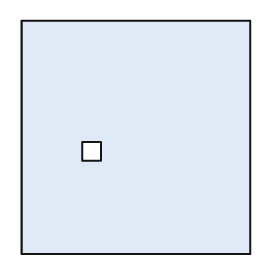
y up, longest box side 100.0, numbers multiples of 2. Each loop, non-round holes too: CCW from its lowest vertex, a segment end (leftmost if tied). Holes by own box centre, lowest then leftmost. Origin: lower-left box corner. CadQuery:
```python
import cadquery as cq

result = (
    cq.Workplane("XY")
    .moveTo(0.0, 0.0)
    .lineTo(98.0, 0.0)
    .lineTo(98.0, 100.0)
    .lineTo(0.0, 100.0)
    .close()
    .moveTo(26.0, 40.0)
    .lineTo(34.0, 40.0)
    .lineTo(34.0, 48.0)
    .lineTo(26.0, 48.0)
    .close()
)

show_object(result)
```